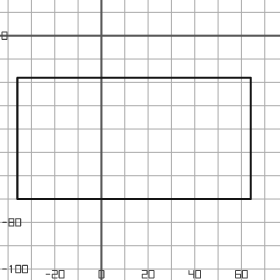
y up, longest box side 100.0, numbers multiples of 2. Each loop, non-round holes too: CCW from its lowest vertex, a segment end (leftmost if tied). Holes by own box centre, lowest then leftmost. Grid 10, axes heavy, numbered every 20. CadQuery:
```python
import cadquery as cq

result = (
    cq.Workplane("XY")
    .moveTo(-36.0, -70.0)
    .lineTo(64.0, -70.0)
    .lineTo(64.0, -18.0)
    .lineTo(-36.0, -18.0)
    .close()
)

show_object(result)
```